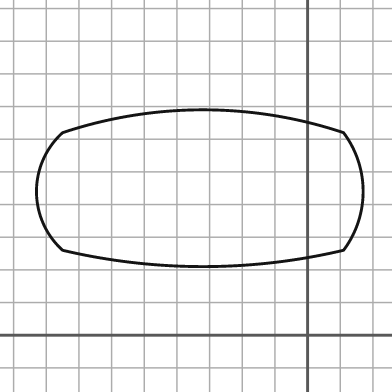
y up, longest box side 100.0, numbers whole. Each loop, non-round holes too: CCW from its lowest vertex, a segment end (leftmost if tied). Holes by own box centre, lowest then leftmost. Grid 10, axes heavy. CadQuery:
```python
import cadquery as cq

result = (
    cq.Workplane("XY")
    .moveTo(-75.0, 26.0)
    .threePointArc((-32.0, 21.0), (11.0, 26.0))
    .threePointArc((17.0, 44.0), (11.0, 62.0))
    .threePointArc((-32.0, 69.0), (-75.0, 62.0))
    .threePointArc((-83.0, 44.0), (-75.0, 26.0))
    .close()
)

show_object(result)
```